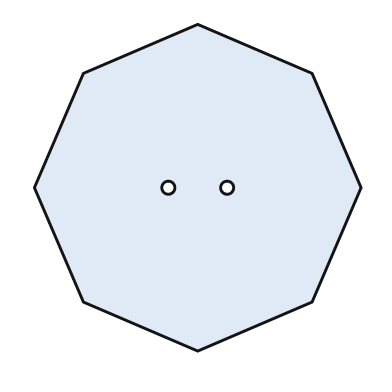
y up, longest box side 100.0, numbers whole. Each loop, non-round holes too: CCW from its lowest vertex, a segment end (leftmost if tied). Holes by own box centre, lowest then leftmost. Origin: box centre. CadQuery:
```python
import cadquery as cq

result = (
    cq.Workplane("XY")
    .moveTo(0.0, -50.0)
    .lineTo(35.0, -35.0)
    .lineTo(50.0, 0.0)
    .lineTo(35.0, 35.0)
    .lineTo(0.0, 50.0)
    .lineTo(-35.0, 35.0)
    .lineTo(-50.0, 0.0)
    .lineTo(-35.0, -35.0)
    .close()
    .moveTo(-9.0, 0.0)
    .circle(2.0)
    .moveTo(9.0, 0.0)
    .circle(2.0)
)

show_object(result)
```